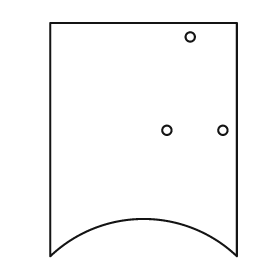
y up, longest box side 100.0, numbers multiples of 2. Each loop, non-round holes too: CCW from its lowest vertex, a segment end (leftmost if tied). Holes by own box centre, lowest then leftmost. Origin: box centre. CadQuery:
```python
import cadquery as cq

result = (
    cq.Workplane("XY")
    .moveTo(-40.0, -50.0)
    .threePointArc((0.0, -34.0), (40.0, -50.0))
    .lineTo(40.0, 50.0)
    .lineTo(-40.0, 50.0)
    .close()
    .moveTo(10.0, 4.0)
    .circle(2.0)
    .moveTo(34.0, 4.0)
    .circle(2.0)
    .moveTo(20.0, 44.0)
    .circle(2.0)
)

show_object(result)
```